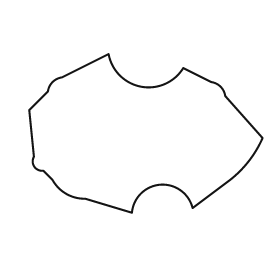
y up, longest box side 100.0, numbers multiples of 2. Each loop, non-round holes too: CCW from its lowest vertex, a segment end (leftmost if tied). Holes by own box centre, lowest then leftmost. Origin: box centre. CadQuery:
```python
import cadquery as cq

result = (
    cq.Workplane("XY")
    .moveTo(-6.0, -34.0)
    .threePointArc((6.0, -22.0), (20.0, -32.0))
    .lineTo(36.0, -20.0)
    .threePointArc((44.0, -12.0), (50.0, -2.0))
    .lineTo(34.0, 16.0)
    .threePointArc((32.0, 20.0), (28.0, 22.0))
    .lineTo(16.0, 28.0)
    .threePointArc((-2.0, 20.0), (-16.0, 34.0))
    .lineTo(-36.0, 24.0)
    .threePointArc((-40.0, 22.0), (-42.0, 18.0))
    .lineTo(-50.0, 10.0)
    .lineTo(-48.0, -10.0)
    .threePointArc((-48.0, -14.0), (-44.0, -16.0))
    .lineTo(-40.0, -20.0)
    .threePointArc((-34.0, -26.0), (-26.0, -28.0))
    .close()
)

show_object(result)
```